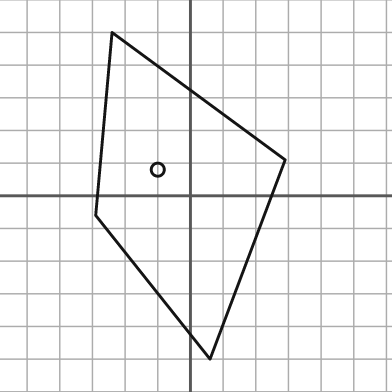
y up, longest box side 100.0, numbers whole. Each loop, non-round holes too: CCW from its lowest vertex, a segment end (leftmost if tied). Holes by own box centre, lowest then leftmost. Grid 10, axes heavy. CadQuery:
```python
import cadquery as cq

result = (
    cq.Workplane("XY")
    .moveTo(6.0, -50.0)
    .lineTo(29.0, 11.0)
    .lineTo(-24.0, 50.0)
    .lineTo(-29.0, -6.0)
    .close()
    .moveTo(-10.0, 8.0)
    .circle(2.0)
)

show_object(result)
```